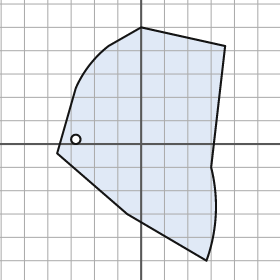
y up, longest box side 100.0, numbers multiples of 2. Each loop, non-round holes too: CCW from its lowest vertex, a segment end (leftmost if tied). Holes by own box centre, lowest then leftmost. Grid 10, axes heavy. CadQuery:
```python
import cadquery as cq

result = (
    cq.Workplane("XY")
    .moveTo(28.0, -50.0)
    .threePointArc((32.0, -30.0), (30.0, -10.0))
    .lineTo(36.0, 42.0)
    .lineTo(0.0, 50.0)
    .lineTo(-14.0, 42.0)
    .threePointArc((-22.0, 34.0), (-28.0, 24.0))
    .lineTo(-36.0, -4.0)
    .lineTo(-6.0, -30.0)
    .close()
    .moveTo(-28.0, 2.0)
    .circle(2.0)
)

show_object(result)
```